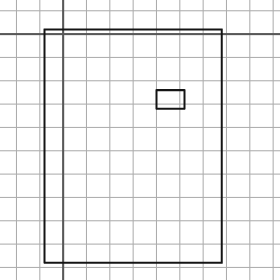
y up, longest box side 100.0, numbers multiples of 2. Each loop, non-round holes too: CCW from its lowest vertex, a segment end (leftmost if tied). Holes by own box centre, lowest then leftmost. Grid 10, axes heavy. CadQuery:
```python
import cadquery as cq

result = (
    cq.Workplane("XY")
    .moveTo(-8.0, -98.0)
    .lineTo(68.0, -98.0)
    .lineTo(68.0, 2.0)
    .lineTo(-8.0, 2.0)
    .close()
    .moveTo(40.0, -32.0)
    .lineTo(52.0, -32.0)
    .lineTo(52.0, -24.0)
    .lineTo(40.0, -24.0)
    .close()
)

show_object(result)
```